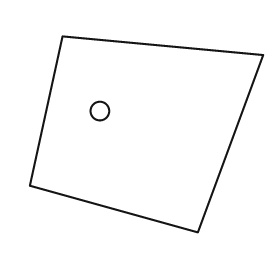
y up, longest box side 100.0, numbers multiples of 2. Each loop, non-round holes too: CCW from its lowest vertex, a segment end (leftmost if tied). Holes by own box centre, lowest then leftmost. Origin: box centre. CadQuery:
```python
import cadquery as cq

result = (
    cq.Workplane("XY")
    .moveTo(22.0, -42.0)
    .lineTo(50.0, 34.0)
    .lineTo(-36.0, 42.0)
    .lineTo(-50.0, -22.0)
    .close()
    .moveTo(-20.0, 10.0)
    .circle(4.0)
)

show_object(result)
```